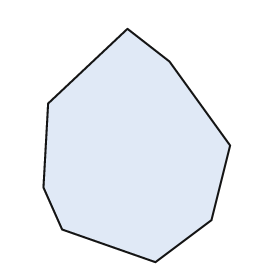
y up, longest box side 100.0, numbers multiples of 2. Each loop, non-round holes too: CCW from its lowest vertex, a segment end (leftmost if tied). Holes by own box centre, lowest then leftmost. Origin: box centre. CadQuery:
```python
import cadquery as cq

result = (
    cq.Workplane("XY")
    .moveTo(8.0, -50.0)
    .lineTo(32.0, -32.0)
    .lineTo(40.0, 0.0)
    .lineTo(14.0, 36.0)
    .lineTo(-4.0, 50.0)
    .lineTo(-38.0, 18.0)
    .lineTo(-40.0, -18.0)
    .lineTo(-32.0, -36.0)
    .close()
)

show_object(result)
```